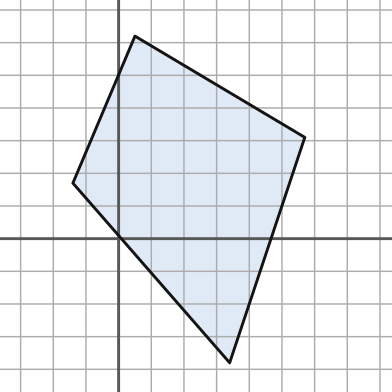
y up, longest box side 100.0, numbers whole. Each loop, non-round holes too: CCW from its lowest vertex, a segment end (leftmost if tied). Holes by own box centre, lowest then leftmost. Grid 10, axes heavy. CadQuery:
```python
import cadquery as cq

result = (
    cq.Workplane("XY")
    .moveTo(34.0, -38.0)
    .lineTo(57.0, 31.0)
    .lineTo(5.0, 62.0)
    .lineTo(-14.0, 17.0)
    .close()
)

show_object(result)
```